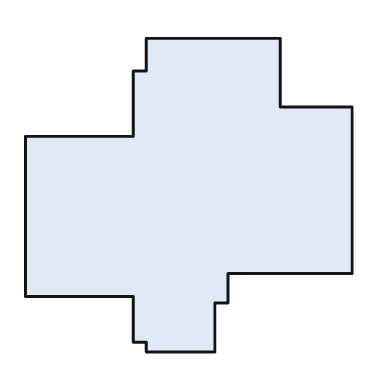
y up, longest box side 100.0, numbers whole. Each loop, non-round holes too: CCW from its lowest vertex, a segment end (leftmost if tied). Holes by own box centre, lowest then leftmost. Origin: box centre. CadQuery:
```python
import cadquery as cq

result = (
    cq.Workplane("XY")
    .moveTo(-13.0, -48.0)
    .lineTo(8.0, -48.0)
    .lineTo(8.0, -33.0)
    .lineTo(12.0, -33.0)
    .lineTo(12.0, -24.0)
    .lineTo(50.0, -24.0)
    .lineTo(50.0, 27.0)
    .lineTo(28.0, 27.0)
    .lineTo(28.0, 48.0)
    .lineTo(-13.0, 48.0)
    .lineTo(-13.0, 38.0)
    .lineTo(-17.0, 38.0)
    .lineTo(-17.0, 18.0)
    .lineTo(-50.0, 18.0)
    .lineTo(-50.0, -31.0)
    .lineTo(-17.0, -31.0)
    .lineTo(-17.0, -45.0)
    .lineTo(-13.0, -45.0)
    .close()
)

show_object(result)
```